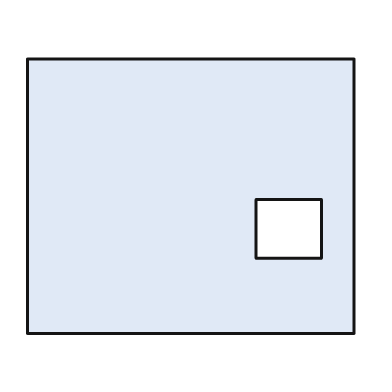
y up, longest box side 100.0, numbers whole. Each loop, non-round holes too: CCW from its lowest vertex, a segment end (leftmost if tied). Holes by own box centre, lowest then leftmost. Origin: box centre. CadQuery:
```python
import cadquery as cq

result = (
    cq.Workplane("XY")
    .moveTo(-50.0, -42.0)
    .lineTo(50.0, -42.0)
    .lineTo(50.0, 42.0)
    .lineTo(-50.0, 42.0)
    .close()
    .moveTo(20.0, -19.0)
    .lineTo(40.0, -19.0)
    .lineTo(40.0, -1.0)
    .lineTo(20.0, -1.0)
    .close()
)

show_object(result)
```